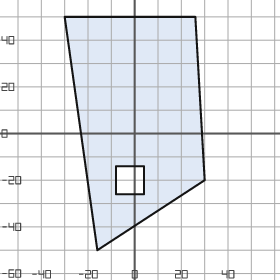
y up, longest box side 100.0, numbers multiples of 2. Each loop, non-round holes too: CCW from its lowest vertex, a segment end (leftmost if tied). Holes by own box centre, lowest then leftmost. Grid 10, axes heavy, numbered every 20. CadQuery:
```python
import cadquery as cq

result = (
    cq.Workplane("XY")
    .moveTo(-16.0, -50.0)
    .lineTo(30.0, -20.0)
    .lineTo(26.0, 50.0)
    .lineTo(-30.0, 50.0)
    .close()
    .moveTo(-8.0, -26.0)
    .lineTo(4.0, -26.0)
    .lineTo(4.0, -14.0)
    .lineTo(-8.0, -14.0)
    .close()
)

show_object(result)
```